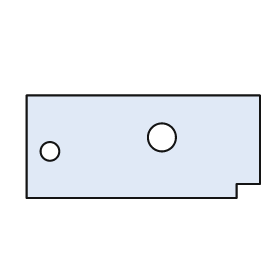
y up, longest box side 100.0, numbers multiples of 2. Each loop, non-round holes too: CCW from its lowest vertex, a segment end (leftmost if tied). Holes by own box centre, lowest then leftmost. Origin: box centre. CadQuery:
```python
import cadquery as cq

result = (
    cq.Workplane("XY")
    .moveTo(-50.0, -22.0)
    .lineTo(40.0, -22.0)
    .lineTo(40.0, -16.0)
    .lineTo(50.0, -16.0)
    .lineTo(50.0, 22.0)
    .lineTo(-50.0, 22.0)
    .close()
    .moveTo(-40.0, -2.0)
    .circle(4.0)
    .moveTo(8.0, 4.0)
    .circle(6.0)
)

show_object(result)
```